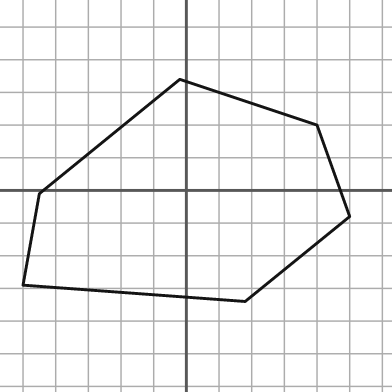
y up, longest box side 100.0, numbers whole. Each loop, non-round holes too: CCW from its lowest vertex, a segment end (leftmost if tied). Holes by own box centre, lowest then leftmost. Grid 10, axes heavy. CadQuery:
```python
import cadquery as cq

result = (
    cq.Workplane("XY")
    .moveTo(18.0, -34.0)
    .lineTo(50.0, -8.0)
    .lineTo(40.0, 20.0)
    .lineTo(-2.0, 34.0)
    .lineTo(-45.0, -1.0)
    .lineTo(-50.0, -29.0)
    .close()
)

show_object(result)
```